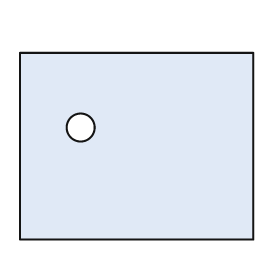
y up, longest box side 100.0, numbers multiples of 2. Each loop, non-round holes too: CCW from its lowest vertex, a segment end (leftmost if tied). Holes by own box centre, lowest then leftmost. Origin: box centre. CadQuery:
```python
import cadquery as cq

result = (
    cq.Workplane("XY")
    .moveTo(-50.0, -40.0)
    .lineTo(50.0, -40.0)
    .lineTo(50.0, 40.0)
    .lineTo(-50.0, 40.0)
    .close()
    .moveTo(-24.0, 8.0)
    .circle(6.0)
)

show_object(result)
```